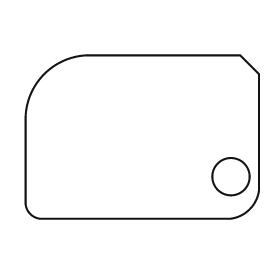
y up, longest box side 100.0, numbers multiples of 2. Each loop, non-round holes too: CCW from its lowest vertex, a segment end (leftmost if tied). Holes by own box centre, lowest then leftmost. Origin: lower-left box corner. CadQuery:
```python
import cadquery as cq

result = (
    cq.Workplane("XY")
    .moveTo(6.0, 0.0)
    .lineTo(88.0, 0.0)
    .threePointArc((96.0, 4.0), (100.0, 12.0))
    .lineTo(100.0, 62.0)
    .lineTo(92.0, 70.0)
    .lineTo(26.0, 70.0)
    .threePointArc((8.0, 62.0), (0.0, 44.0))
    .lineTo(0.0, 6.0)
    .threePointArc((2.0, 2.0), (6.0, 0.0))
    .close()
    .moveTo(88.0, 18.0)
    .circle(8.0)
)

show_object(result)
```